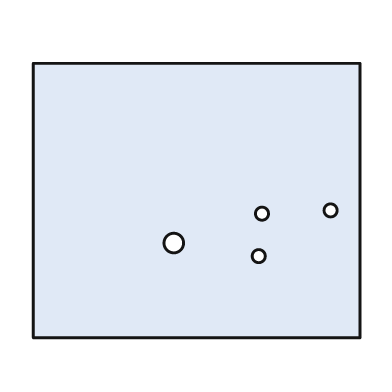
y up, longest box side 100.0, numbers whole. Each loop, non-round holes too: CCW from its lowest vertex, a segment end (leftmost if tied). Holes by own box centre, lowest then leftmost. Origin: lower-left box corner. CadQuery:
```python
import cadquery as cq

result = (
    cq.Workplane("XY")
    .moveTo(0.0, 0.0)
    .lineTo(100.0, 0.0)
    .lineTo(100.0, 84.0)
    .lineTo(0.0, 84.0)
    .close()
    .moveTo(69.0, 25.0)
    .circle(2.0)
    .moveTo(43.0, 29.0)
    .circle(3.0)
    .moveTo(70.0, 38.0)
    .circle(2.0)
    .moveTo(91.0, 39.0)
    .circle(2.0)
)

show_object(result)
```